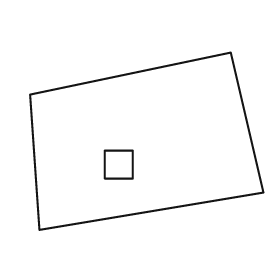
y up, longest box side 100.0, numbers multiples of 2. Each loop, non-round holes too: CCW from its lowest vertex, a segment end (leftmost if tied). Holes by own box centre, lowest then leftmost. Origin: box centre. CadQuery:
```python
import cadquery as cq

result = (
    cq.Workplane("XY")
    .moveTo(-46.0, -38.0)
    .lineTo(50.0, -22.0)
    .lineTo(36.0, 38.0)
    .lineTo(-50.0, 20.0)
    .close()
    .moveTo(-18.0, -16.0)
    .lineTo(-6.0, -16.0)
    .lineTo(-6.0, -4.0)
    .lineTo(-18.0, -4.0)
    .close()
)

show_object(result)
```